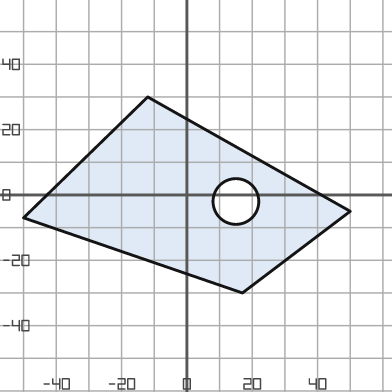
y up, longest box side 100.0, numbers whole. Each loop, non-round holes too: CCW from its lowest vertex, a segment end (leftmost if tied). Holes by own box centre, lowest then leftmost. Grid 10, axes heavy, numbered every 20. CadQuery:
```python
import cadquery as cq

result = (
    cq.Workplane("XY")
    .moveTo(17.0, -30.0)
    .lineTo(50.0, -5.0)
    .lineTo(-12.0, 30.0)
    .lineTo(-50.0, -7.0)
    .close()
    .moveTo(15.0, -2.0)
    .circle(7.0)
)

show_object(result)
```